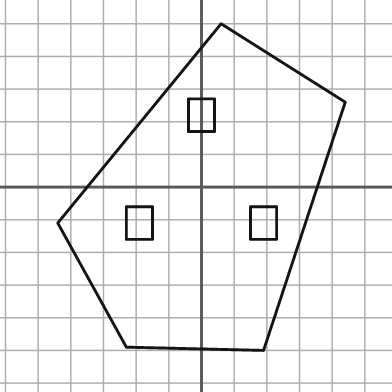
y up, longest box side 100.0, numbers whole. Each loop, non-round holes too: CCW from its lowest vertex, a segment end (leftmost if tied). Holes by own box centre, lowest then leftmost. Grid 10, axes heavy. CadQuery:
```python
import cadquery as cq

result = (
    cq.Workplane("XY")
    .moveTo(19.0, -50.0)
    .lineTo(44.0, 26.0)
    .lineTo(6.0, 50.0)
    .lineTo(-44.0, -11.0)
    .lineTo(-23.0, -49.0)
    .close()
    .moveTo(-23.0, -16.0)
    .lineTo(-15.0, -16.0)
    .lineTo(-15.0, -6.0)
    .lineTo(-23.0, -6.0)
    .close()
    .moveTo(15.0, -16.0)
    .lineTo(23.0, -16.0)
    .lineTo(23.0, -6.0)
    .lineTo(15.0, -6.0)
    .close()
    .moveTo(-4.0, 17.0)
    .lineTo(4.0, 17.0)
    .lineTo(4.0, 27.0)
    .lineTo(-4.0, 27.0)
    .close()
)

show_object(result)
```